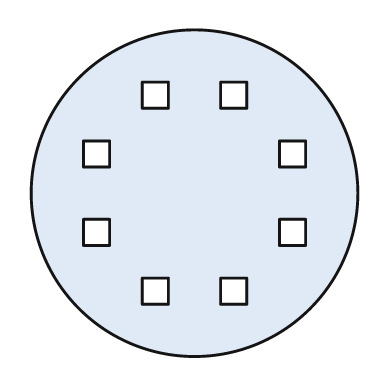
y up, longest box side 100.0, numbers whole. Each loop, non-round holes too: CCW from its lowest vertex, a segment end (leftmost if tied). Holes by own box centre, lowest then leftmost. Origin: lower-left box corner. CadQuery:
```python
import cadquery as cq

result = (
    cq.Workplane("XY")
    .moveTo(50.0, 50.0)
    .circle(50.0)
    .moveTo(34.0, 16.0)
    .lineTo(42.0, 16.0)
    .lineTo(42.0, 24.0)
    .lineTo(34.0, 24.0)
    .close()
    .moveTo(58.0, 16.0)
    .lineTo(66.0, 16.0)
    .lineTo(66.0, 24.0)
    .lineTo(58.0, 24.0)
    .close()
    .moveTo(16.0, 34.0)
    .lineTo(24.0, 34.0)
    .lineTo(24.0, 42.0)
    .lineTo(16.0, 42.0)
    .close()
    .moveTo(76.0, 34.0)
    .lineTo(84.0, 34.0)
    .lineTo(84.0, 42.0)
    .lineTo(76.0, 42.0)
    .close()
    .moveTo(16.0, 58.0)
    .lineTo(24.0, 58.0)
    .lineTo(24.0, 66.0)
    .lineTo(16.0, 66.0)
    .close()
    .moveTo(76.0, 58.0)
    .lineTo(84.0, 58.0)
    .lineTo(84.0, 66.0)
    .lineTo(76.0, 66.0)
    .close()
    .moveTo(34.0, 76.0)
    .lineTo(42.0, 76.0)
    .lineTo(42.0, 84.0)
    .lineTo(34.0, 84.0)
    .close()
    .moveTo(58.0, 76.0)
    .lineTo(66.0, 76.0)
    .lineTo(66.0, 84.0)
    .lineTo(58.0, 84.0)
    .close()
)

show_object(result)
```